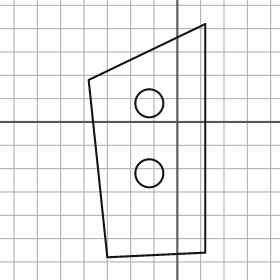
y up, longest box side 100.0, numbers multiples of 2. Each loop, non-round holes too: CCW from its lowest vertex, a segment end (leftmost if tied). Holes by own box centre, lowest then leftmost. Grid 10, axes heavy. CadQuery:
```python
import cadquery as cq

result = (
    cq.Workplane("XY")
    .moveTo(-30.0, -58.0)
    .lineTo(12.0, -56.0)
    .lineTo(12.0, 42.0)
    .lineTo(-38.0, 18.0)
    .close()
    .moveTo(-12.0, -22.0)
    .circle(6.0)
    .moveTo(-12.0, 8.0)
    .circle(6.0)
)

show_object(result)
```